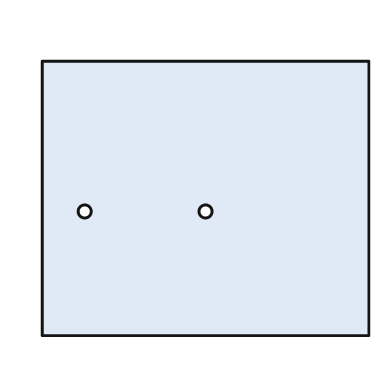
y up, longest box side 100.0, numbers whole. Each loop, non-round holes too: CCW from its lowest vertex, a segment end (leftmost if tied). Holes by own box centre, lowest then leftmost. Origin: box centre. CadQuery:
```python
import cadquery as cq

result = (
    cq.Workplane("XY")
    .moveTo(-50.0, -42.0)
    .lineTo(50.0, -42.0)
    .lineTo(50.0, 42.0)
    .lineTo(-50.0, 42.0)
    .close()
    .moveTo(-37.0, -4.0)
    .circle(2.0)
    .moveTo(0.0, -4.0)
    .circle(2.0)
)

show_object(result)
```